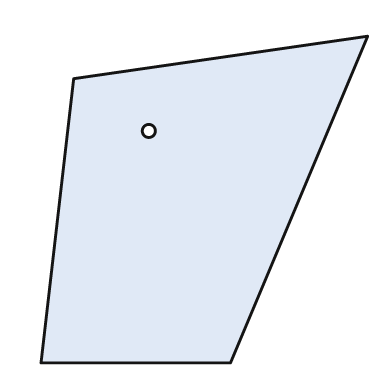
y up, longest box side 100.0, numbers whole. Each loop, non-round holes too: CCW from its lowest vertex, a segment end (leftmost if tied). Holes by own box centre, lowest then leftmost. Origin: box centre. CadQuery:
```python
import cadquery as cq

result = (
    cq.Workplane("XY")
    .moveTo(-50.0, -50.0)
    .lineTo(8.0, -50.0)
    .lineTo(50.0, 50.0)
    .lineTo(-40.0, 37.0)
    .close()
    .moveTo(-17.0, 21.0)
    .circle(2.0)
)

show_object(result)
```